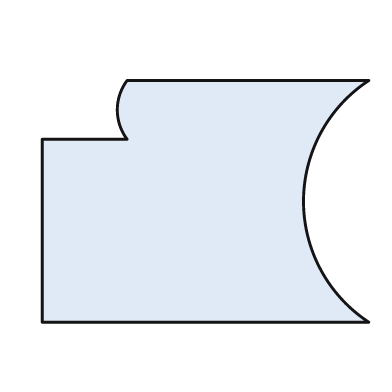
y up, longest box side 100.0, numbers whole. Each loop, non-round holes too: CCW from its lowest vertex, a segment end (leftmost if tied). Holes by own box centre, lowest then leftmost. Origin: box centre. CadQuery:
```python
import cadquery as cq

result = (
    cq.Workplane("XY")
    .moveTo(-50.0, -37.0)
    .lineTo(50.0, -37.0)
    .threePointArc((30.0, 0.0), (50.0, 37.0))
    .lineTo(-24.0, 37.0)
    .threePointArc((-27.0, 28.0), (-24.0, 19.0))
    .lineTo(-50.0, 19.0)
    .close()
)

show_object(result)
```